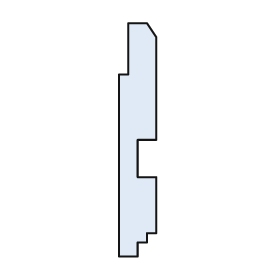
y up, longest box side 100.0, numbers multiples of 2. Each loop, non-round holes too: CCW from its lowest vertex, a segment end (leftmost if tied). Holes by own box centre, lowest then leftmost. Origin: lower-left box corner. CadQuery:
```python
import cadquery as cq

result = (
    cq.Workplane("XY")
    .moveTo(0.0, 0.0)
    .lineTo(8.0, 0.0)
    .lineTo(8.0, 6.0)
    .lineTo(12.0, 6.0)
    .lineTo(12.0, 10.0)
    .lineTo(16.0, 10.0)
    .lineTo(16.0, 34.0)
    .lineTo(8.0, 34.0)
    .lineTo(8.0, 50.0)
    .lineTo(16.0, 50.0)
    .lineTo(16.0, 94.0)
    .lineTo(12.0, 100.0)
    .lineTo(4.0, 100.0)
    .lineTo(4.0, 78.0)
    .lineTo(0.0, 78.0)
    .close()
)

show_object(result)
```